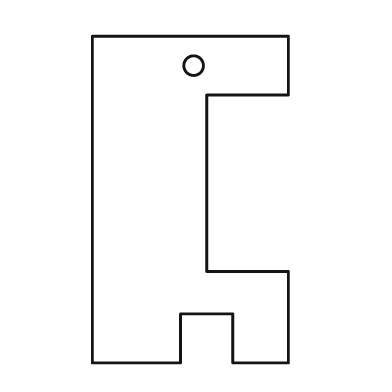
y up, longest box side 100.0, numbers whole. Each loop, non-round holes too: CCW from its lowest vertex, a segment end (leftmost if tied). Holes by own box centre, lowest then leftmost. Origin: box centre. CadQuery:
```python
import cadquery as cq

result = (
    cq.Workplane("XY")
    .moveTo(-30.0, -50.0)
    .lineTo(-3.0, -50.0)
    .lineTo(-3.0, -35.0)
    .lineTo(13.0, -35.0)
    .lineTo(13.0, -50.0)
    .lineTo(30.0, -50.0)
    .lineTo(30.0, -22.0)
    .lineTo(5.0, -22.0)
    .lineTo(5.0, 32.0)
    .lineTo(30.0, 32.0)
    .lineTo(30.0, 50.0)
    .lineTo(-30.0, 50.0)
    .close()
    .moveTo(1.0, 41.0)
    .circle(3.0)
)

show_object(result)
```